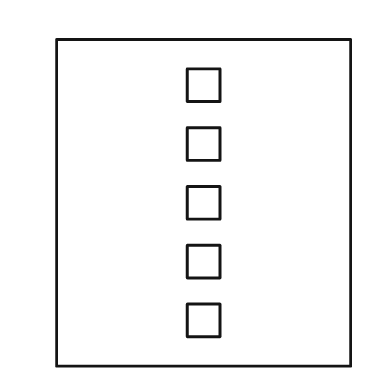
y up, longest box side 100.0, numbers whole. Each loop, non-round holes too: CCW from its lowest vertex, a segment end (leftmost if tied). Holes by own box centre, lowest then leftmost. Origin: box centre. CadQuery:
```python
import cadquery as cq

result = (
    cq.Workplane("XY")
    .moveTo(-45.0, -50.0)
    .lineTo(45.0, -50.0)
    .lineTo(45.0, 50.0)
    .lineTo(-45.0, 50.0)
    .close()
    .moveTo(-5.0, -41.0)
    .lineTo(5.0, -41.0)
    .lineTo(5.0, -31.0)
    .lineTo(-5.0, -31.0)
    .close()
    .moveTo(-5.0, -23.0)
    .lineTo(5.0, -23.0)
    .lineTo(5.0, -13.0)
    .lineTo(-5.0, -13.0)
    .close()
    .moveTo(-5.0, -5.0)
    .lineTo(5.0, -5.0)
    .lineTo(5.0, 5.0)
    .lineTo(-5.0, 5.0)
    .close()
    .moveTo(-5.0, 13.0)
    .lineTo(5.0, 13.0)
    .lineTo(5.0, 23.0)
    .lineTo(-5.0, 23.0)
    .close()
    .moveTo(-5.0, 31.0)
    .lineTo(5.0, 31.0)
    .lineTo(5.0, 41.0)
    .lineTo(-5.0, 41.0)
    .close()
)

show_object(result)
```